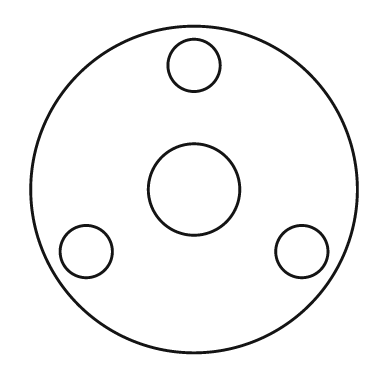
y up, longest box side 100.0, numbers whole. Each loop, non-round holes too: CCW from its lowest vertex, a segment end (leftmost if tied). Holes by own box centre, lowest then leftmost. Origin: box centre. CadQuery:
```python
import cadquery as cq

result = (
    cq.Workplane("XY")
    .moveTo(0.0, 0.0)
    .circle(50.0)
    .moveTo(-33.0, -19.0)
    .circle(8.0)
    .moveTo(33.0, -19.0)
    .circle(8.0)
    .moveTo(0.0, 0.0)
    .circle(14.0)
    .moveTo(0.0, 38.0)
    .circle(8.0)
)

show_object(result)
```